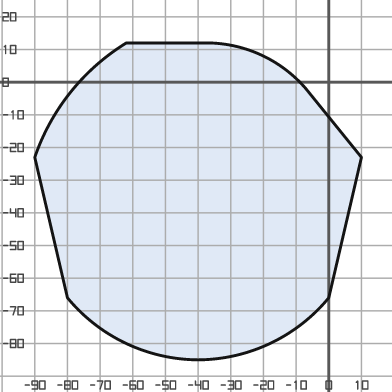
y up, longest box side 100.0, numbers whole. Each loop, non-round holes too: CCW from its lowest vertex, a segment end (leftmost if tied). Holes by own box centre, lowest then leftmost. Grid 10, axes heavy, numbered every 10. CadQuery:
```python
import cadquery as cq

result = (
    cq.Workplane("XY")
    .moveTo(-40.0, -85.0)
    .threePointArc((-18.0, -80.0), (0.0, -66.0))
    .lineTo(10.0, -23.0)
    .lineTo(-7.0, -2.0)
    .threePointArc((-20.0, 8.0), (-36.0, 12.0))
    .lineTo(-62.0, 12.0)
    .threePointArc((-79.0, -3.0), (-90.0, -23.0))
    .lineTo(-80.0, -66.0)
    .threePointArc((-62.0, -80.0), (-40.0, -85.0))
    .close()
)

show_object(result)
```